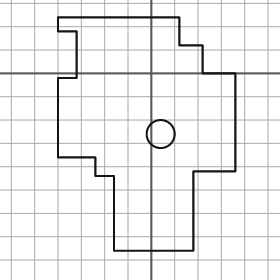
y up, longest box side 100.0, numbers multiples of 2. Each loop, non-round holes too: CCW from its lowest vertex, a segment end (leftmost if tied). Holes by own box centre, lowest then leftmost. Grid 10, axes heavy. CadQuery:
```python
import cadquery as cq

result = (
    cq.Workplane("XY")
    .moveTo(-16.0, -76.0)
    .lineTo(18.0, -76.0)
    .lineTo(18.0, -42.0)
    .lineTo(36.0, -42.0)
    .lineTo(36.0, 0.0)
    .lineTo(22.0, 0.0)
    .lineTo(22.0, 12.0)
    .lineTo(12.0, 12.0)
    .lineTo(12.0, 24.0)
    .lineTo(-40.0, 24.0)
    .lineTo(-40.0, 18.0)
    .lineTo(-32.0, 18.0)
    .lineTo(-32.0, -2.0)
    .lineTo(-40.0, -2.0)
    .lineTo(-40.0, -36.0)
    .lineTo(-24.0, -36.0)
    .lineTo(-24.0, -44.0)
    .lineTo(-16.0, -44.0)
    .close()
    .moveTo(4.0, -26.0)
    .circle(6.0)
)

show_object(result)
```